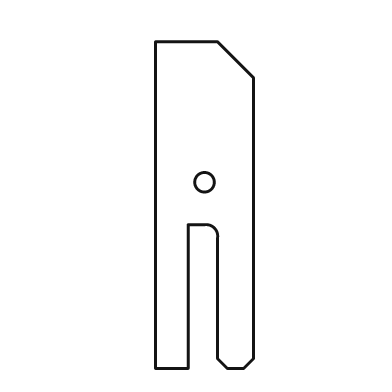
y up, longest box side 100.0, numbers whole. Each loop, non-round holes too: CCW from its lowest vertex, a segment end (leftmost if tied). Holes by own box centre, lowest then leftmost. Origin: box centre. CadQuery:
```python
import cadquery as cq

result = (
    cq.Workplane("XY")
    .moveTo(-15.0, -50.0)
    .lineTo(-5.0, -50.0)
    .lineTo(-5.0, -6.0)
    .lineTo(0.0, -6.0)
    .threePointArc((3.0, -7.0), (4.0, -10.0))
    .lineTo(4.0, -47.0)
    .lineTo(7.0, -50.0)
    .lineTo(12.0, -50.0)
    .lineTo(15.0, -47.0)
    .lineTo(15.0, 39.0)
    .lineTo(4.0, 50.0)
    .lineTo(-15.0, 50.0)
    .close()
    .moveTo(0.0, 7.0)
    .circle(3.0)
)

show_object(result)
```